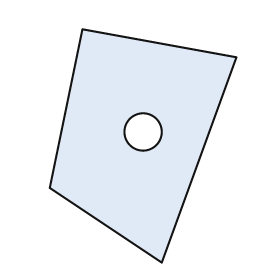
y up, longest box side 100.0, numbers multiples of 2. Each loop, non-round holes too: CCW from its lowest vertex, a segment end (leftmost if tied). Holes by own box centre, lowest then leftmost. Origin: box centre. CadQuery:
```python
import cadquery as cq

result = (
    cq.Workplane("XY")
    .moveTo(8.0, -50.0)
    .lineTo(40.0, 38.0)
    .lineTo(-26.0, 50.0)
    .lineTo(-40.0, -18.0)
    .close()
    .moveTo(0.0, 6.0)
    .circle(8.0)
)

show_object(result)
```